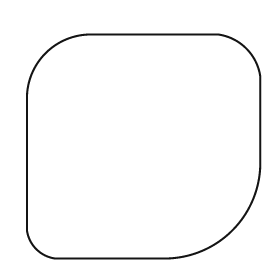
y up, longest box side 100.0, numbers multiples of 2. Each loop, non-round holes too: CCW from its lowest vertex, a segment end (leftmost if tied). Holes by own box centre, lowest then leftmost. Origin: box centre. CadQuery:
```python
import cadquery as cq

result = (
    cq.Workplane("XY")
    .moveTo(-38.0, -48.0)
    .lineTo(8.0, -48.0)
    .threePointArc((38.0, -36.0), (50.0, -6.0))
    .lineTo(50.0, 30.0)
    .threePointArc((44.0, 42.0), (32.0, 48.0))
    .lineTo(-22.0, 48.0)
    .threePointArc((-42.0, 40.0), (-50.0, 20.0))
    .lineTo(-50.0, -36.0)
    .threePointArc((-46.0, -44.0), (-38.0, -48.0))
    .close()
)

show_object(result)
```